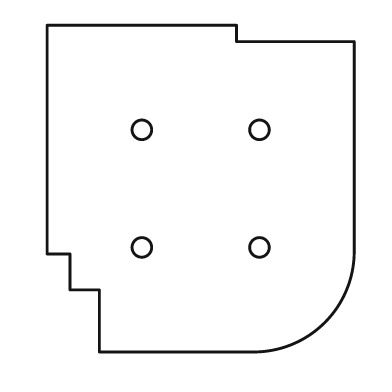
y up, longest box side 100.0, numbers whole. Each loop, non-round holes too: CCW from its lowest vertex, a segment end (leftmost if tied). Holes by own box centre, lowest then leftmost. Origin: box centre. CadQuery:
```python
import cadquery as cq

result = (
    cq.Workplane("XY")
    .moveTo(-31.0, -50.0)
    .lineTo(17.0, -50.0)
    .threePointArc((38.0, -41.0), (47.0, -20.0))
    .lineTo(47.0, 45.0)
    .lineTo(11.0, 45.0)
    .lineTo(11.0, 50.0)
    .lineTo(-47.0, 50.0)
    .lineTo(-47.0, -20.0)
    .lineTo(-40.0, -20.0)
    .lineTo(-40.0, -31.0)
    .lineTo(-31.0, -31.0)
    .close()
    .moveTo(-18.0, -18.0)
    .circle(3.0)
    .moveTo(18.0, -18.0)
    .circle(3.0)
    .moveTo(-18.0, 18.0)
    .circle(3.0)
    .moveTo(18.0, 18.0)
    .circle(3.0)
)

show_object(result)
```